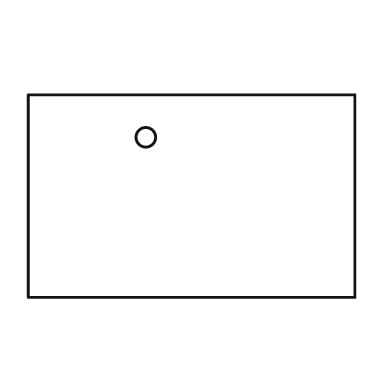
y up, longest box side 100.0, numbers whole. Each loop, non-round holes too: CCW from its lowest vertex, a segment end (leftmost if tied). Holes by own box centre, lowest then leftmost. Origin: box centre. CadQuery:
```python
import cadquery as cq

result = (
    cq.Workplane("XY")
    .moveTo(-50.0, -31.0)
    .lineTo(50.0, -31.0)
    .lineTo(50.0, 31.0)
    .lineTo(-50.0, 31.0)
    .close()
    .moveTo(-14.0, 18.0)
    .circle(3.0)
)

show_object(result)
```